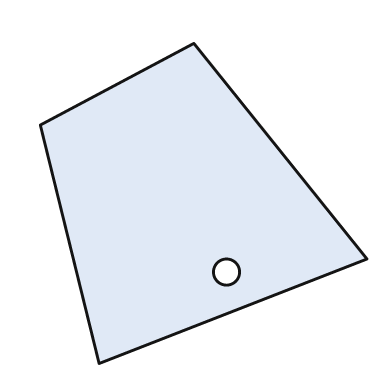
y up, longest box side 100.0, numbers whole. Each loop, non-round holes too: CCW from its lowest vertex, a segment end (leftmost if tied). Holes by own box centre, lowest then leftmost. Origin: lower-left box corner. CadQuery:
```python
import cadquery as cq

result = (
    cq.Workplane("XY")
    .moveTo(18.0, 0.0)
    .lineTo(100.0, 32.0)
    .lineTo(47.0, 98.0)
    .lineTo(0.0, 73.0)
    .close()
    .moveTo(57.0, 28.0)
    .circle(4.0)
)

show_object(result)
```